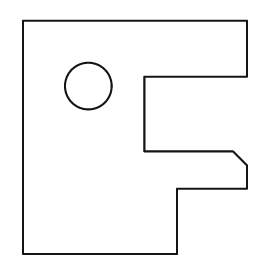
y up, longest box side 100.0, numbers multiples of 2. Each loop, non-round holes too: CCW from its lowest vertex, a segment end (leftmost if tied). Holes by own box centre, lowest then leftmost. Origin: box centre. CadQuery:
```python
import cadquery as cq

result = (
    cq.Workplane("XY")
    .moveTo(-48.0, -50.0)
    .lineTo(18.0, -50.0)
    .lineTo(18.0, -22.0)
    .lineTo(48.0, -22.0)
    .lineTo(48.0, -12.0)
    .lineTo(42.0, -6.0)
    .lineTo(4.0, -6.0)
    .lineTo(4.0, 26.0)
    .lineTo(48.0, 26.0)
    .lineTo(48.0, 50.0)
    .lineTo(-48.0, 50.0)
    .close()
    .moveTo(-20.0, 22.0)
    .circle(10.0)
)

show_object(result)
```